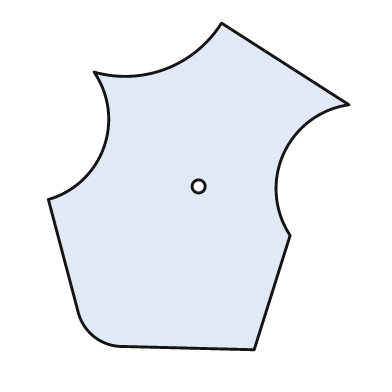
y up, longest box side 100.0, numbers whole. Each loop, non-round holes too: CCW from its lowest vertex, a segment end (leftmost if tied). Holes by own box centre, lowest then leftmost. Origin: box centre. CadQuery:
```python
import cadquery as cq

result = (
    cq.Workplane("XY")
    .moveTo(17.0, -50.0)
    .lineTo(28.0, -15.0)
    .threePointArc((26.0, 10.0), (46.0, 25.0))
    .lineTo(7.0, 50.0)
    .threePointArc((-10.0, 36.0), (-32.0, 35.0))
    .threePointArc((-29.0, 12.0), (-46.0, -4.0))
    .lineTo(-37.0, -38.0)
    .threePointArc((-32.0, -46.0), (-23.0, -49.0))
    .close()
    .moveTo(0.0, 0.0)
    .circle(2.0)
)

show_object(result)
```